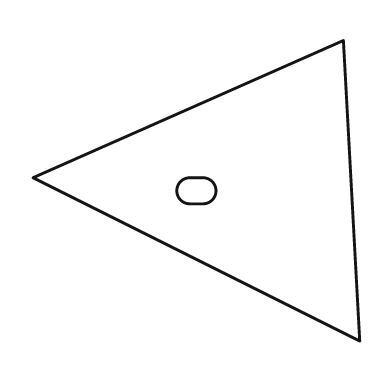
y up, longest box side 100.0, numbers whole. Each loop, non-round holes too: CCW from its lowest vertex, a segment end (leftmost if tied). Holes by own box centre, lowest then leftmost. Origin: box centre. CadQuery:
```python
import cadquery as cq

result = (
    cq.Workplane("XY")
    .moveTo(50.0, -46.0)
    .lineTo(45.0, 46.0)
    .lineTo(-50.0, 4.0)
    .close()
    .moveTo(-2.0, -4.0)
    .lineTo(2.0, -4.0)
    .threePointArc((6.0, 0.0), (2.0, 4.0))
    .lineTo(-2.0, 4.0)
    .threePointArc((-6.0, 0.0), (-2.0, -4.0))
    .close()
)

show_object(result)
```